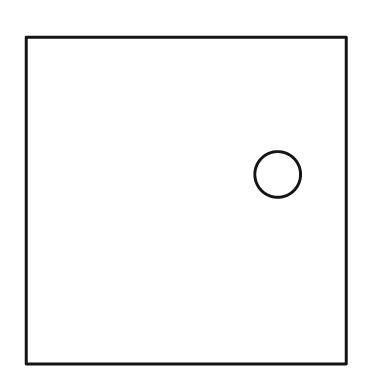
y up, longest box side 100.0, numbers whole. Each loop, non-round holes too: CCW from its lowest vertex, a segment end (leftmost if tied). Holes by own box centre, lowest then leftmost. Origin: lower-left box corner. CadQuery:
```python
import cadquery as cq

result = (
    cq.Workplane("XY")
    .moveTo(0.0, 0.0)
    .lineTo(98.0, 0.0)
    .lineTo(98.0, 100.0)
    .lineTo(0.0, 100.0)
    .close()
    .moveTo(77.0, 58.0)
    .circle(7.0)
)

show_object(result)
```